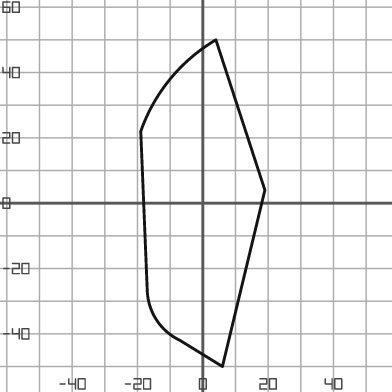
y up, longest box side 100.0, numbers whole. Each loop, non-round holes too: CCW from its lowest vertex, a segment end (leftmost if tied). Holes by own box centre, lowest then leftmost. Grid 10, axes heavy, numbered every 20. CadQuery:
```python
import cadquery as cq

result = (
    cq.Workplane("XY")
    .moveTo(6.0, -50.0)
    .lineTo(19.0, 4.0)
    .lineTo(4.0, 50.0)
    .threePointArc((-10.0, 38.0), (-19.0, 22.0))
    .lineTo(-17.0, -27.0)
    .threePointArc((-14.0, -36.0), (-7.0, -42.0))
    .close()
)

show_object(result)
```